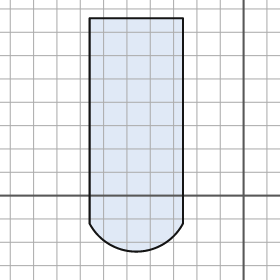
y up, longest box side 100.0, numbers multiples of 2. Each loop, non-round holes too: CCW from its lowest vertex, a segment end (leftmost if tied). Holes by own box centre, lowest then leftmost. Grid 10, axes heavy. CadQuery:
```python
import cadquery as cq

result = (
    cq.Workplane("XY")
    .moveTo(-66.0, -12.0)
    .threePointArc((-46.0, -24.0), (-26.0, -12.0))
    .lineTo(-26.0, 76.0)
    .lineTo(-66.0, 76.0)
    .close()
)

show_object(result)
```